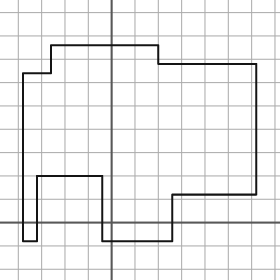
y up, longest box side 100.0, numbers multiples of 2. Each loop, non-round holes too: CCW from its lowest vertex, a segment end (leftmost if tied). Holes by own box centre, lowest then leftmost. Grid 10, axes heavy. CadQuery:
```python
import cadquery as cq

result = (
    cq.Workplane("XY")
    .moveTo(-38.0, -8.0)
    .lineTo(-32.0, -8.0)
    .lineTo(-32.0, 20.0)
    .lineTo(-4.0, 20.0)
    .lineTo(-4.0, -8.0)
    .lineTo(26.0, -8.0)
    .lineTo(26.0, 12.0)
    .lineTo(62.0, 12.0)
    .lineTo(62.0, 68.0)
    .lineTo(20.0, 68.0)
    .lineTo(20.0, 76.0)
    .lineTo(-26.0, 76.0)
    .lineTo(-26.0, 64.0)
    .lineTo(-38.0, 64.0)
    .close()
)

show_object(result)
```